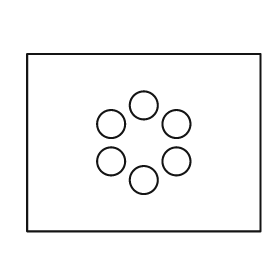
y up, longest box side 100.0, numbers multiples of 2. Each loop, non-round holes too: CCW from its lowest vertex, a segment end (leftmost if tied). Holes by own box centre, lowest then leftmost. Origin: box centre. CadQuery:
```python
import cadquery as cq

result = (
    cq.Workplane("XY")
    .moveTo(-50.0, -38.0)
    .lineTo(50.0, -38.0)
    .lineTo(50.0, 38.0)
    .lineTo(-50.0, 38.0)
    .close()
    .moveTo(0.0, -16.0)
    .circle(6.0)
    .moveTo(-14.0, -8.0)
    .circle(6.0)
    .moveTo(14.0, -8.0)
    .circle(6.0)
    .moveTo(-14.0, 8.0)
    .circle(6.0)
    .moveTo(14.0, 8.0)
    .circle(6.0)
    .moveTo(0.0, 16.0)
    .circle(6.0)
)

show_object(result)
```